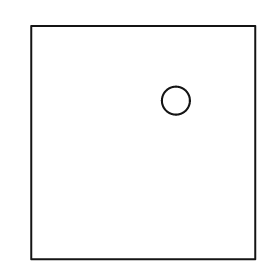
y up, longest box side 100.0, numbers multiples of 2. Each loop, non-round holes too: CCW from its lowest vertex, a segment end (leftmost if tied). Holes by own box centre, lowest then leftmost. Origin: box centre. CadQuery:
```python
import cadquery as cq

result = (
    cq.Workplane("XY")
    .moveTo(-48.0, -50.0)
    .lineTo(48.0, -50.0)
    .lineTo(48.0, 50.0)
    .lineTo(-48.0, 50.0)
    .close()
    .moveTo(14.0, 18.0)
    .circle(6.0)
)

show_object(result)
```